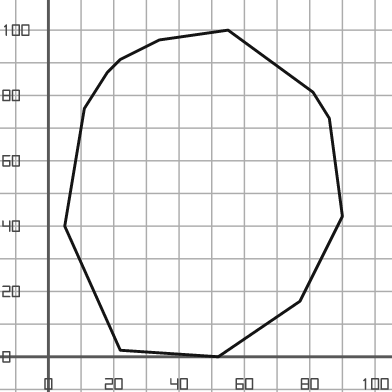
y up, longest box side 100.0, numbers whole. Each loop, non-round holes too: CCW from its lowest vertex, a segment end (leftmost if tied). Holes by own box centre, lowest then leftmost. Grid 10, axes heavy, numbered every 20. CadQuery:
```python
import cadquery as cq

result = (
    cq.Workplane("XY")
    .moveTo(52.0, 0.0)
    .lineTo(77.0, 17.0)
    .lineTo(90.0, 43.0)
    .lineTo(86.0, 73.0)
    .lineTo(81.0, 81.0)
    .lineTo(55.0, 100.0)
    .lineTo(34.0, 97.0)
    .lineTo(22.0, 91.0)
    .lineTo(18.0, 87.0)
    .lineTo(11.0, 76.0)
    .lineTo(5.0, 40.0)
    .lineTo(22.0, 2.0)
    .close()
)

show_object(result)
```